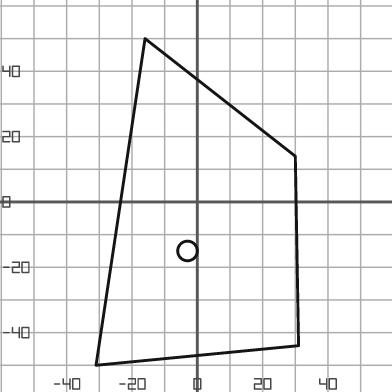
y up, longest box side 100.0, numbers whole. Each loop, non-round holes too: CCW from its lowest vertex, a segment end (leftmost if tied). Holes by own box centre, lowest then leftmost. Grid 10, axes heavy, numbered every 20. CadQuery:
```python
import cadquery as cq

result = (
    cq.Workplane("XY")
    .moveTo(-31.0, -50.0)
    .lineTo(31.0, -44.0)
    .lineTo(30.0, 14.0)
    .lineTo(-16.0, 50.0)
    .close()
    .moveTo(-3.0, -15.0)
    .circle(3.0)
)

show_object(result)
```